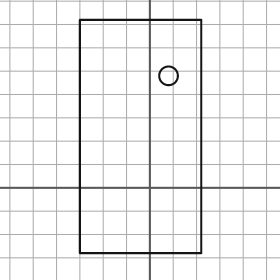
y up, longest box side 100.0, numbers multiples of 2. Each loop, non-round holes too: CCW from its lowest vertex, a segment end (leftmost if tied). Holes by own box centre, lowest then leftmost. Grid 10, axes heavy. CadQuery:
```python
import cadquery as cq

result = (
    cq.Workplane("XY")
    .moveTo(-30.0, -28.0)
    .lineTo(22.0, -28.0)
    .lineTo(22.0, 72.0)
    .lineTo(-30.0, 72.0)
    .close()
    .moveTo(8.0, 48.0)
    .circle(4.0)
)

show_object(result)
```